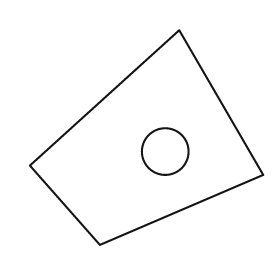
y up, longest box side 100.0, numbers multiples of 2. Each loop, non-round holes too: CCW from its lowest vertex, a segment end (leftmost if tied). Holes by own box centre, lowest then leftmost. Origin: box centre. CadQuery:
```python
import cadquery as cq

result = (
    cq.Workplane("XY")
    .moveTo(-20.0, -46.0)
    .lineTo(50.0, -16.0)
    .lineTo(14.0, 46.0)
    .lineTo(-50.0, -12.0)
    .close()
    .moveTo(8.0, -6.0)
    .circle(10.0)
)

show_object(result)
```